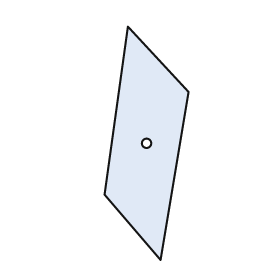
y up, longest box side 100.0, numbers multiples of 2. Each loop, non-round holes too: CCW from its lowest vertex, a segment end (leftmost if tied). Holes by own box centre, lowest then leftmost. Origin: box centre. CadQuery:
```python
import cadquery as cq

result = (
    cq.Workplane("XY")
    .moveTo(6.0, -50.0)
    .lineTo(18.0, 22.0)
    .lineTo(-8.0, 50.0)
    .lineTo(-18.0, -22.0)
    .close()
    .moveTo(0.0, 0.0)
    .circle(2.0)
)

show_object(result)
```